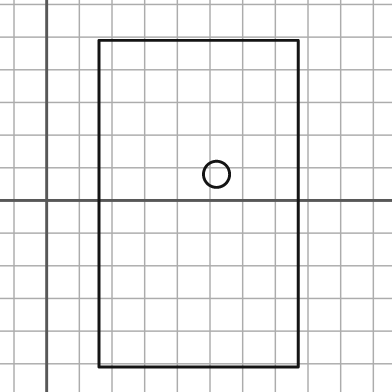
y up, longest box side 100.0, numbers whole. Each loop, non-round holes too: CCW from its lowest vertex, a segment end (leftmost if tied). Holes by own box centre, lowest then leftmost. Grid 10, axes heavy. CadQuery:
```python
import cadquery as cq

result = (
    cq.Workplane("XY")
    .moveTo(16.0, -51.0)
    .lineTo(77.0, -51.0)
    .lineTo(77.0, 49.0)
    .lineTo(16.0, 49.0)
    .close()
    .moveTo(52.0, 8.0)
    .circle(4.0)
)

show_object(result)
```